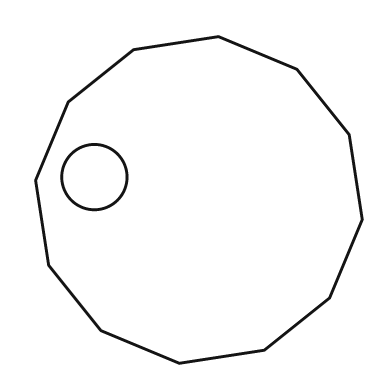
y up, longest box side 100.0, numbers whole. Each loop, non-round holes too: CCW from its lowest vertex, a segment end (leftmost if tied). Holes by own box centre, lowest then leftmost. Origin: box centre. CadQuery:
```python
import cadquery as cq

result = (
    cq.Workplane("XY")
    .moveTo(-6.0, -50.0)
    .lineTo(20.0, -46.0)
    .lineTo(40.0, -30.0)
    .lineTo(50.0, -6.0)
    .lineTo(46.0, 20.0)
    .lineTo(30.0, 40.0)
    .lineTo(6.0, 50.0)
    .lineTo(-20.0, 46.0)
    .lineTo(-40.0, 30.0)
    .lineTo(-50.0, 6.0)
    .lineTo(-46.0, -20.0)
    .lineTo(-30.0, -40.0)
    .close()
    .moveTo(-32.0, 7.0)
    .circle(10.0)
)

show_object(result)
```